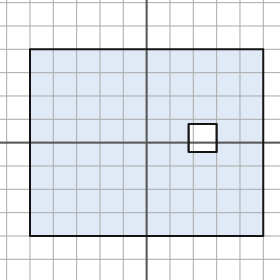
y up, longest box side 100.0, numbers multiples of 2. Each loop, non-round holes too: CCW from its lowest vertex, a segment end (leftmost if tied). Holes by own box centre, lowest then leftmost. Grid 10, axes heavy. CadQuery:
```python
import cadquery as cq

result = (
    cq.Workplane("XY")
    .moveTo(-50.0, -40.0)
    .lineTo(50.0, -40.0)
    .lineTo(50.0, 40.0)
    .lineTo(-50.0, 40.0)
    .close()
    .moveTo(18.0, -4.0)
    .lineTo(30.0, -4.0)
    .lineTo(30.0, 8.0)
    .lineTo(18.0, 8.0)
    .close()
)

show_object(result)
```